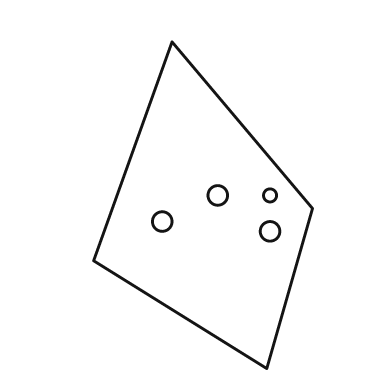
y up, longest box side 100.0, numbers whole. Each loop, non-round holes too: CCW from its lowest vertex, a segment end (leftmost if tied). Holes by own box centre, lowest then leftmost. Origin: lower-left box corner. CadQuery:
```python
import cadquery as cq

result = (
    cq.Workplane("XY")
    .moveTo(53.0, 0.0)
    .lineTo(67.0, 49.0)
    .lineTo(24.0, 100.0)
    .lineTo(0.0, 33.0)
    .close()
    .moveTo(54.0, 42.0)
    .circle(3.0)
    .moveTo(21.0, 45.0)
    .circle(3.0)
    .moveTo(38.0, 53.0)
    .circle(3.0)
    .moveTo(54.0, 53.0)
    .circle(2.0)
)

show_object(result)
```